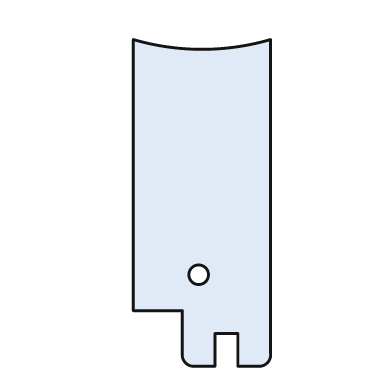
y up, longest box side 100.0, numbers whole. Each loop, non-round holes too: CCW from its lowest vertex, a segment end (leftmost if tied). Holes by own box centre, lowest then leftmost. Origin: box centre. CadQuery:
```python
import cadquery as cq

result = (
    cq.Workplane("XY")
    .moveTo(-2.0, -50.0)
    .lineTo(4.0, -50.0)
    .lineTo(4.0, -40.0)
    .lineTo(11.0, -40.0)
    .lineTo(11.0, -50.0)
    .lineTo(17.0, -50.0)
    .threePointArc((20.0, -49.0), (21.0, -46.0))
    .lineTo(21.0, 50.0)
    .threePointArc((0.0, 47.0), (-21.0, 50.0))
    .lineTo(-21.0, -33.0)
    .lineTo(-6.0, -33.0)
    .lineTo(-6.0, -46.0)
    .threePointArc((-5.0, -49.0), (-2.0, -50.0))
    .close()
    .moveTo(-1.0, -22.0)
    .circle(3.0)
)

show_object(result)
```